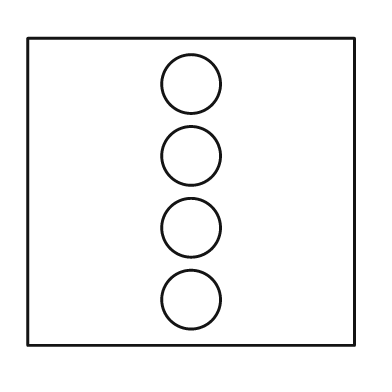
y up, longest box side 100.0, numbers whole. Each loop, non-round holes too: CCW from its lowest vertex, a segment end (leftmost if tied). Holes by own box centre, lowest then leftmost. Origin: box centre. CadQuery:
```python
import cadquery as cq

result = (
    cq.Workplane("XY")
    .moveTo(-50.0, -47.0)
    .lineTo(50.0, -47.0)
    .lineTo(50.0, 47.0)
    .lineTo(-50.0, 47.0)
    .close()
    .moveTo(0.0, -33.0)
    .circle(9.0)
    .moveTo(0.0, -11.0)
    .circle(9.0)
    .moveTo(0.0, 11.0)
    .circle(9.0)
    .moveTo(0.0, 33.0)
    .circle(9.0)
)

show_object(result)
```